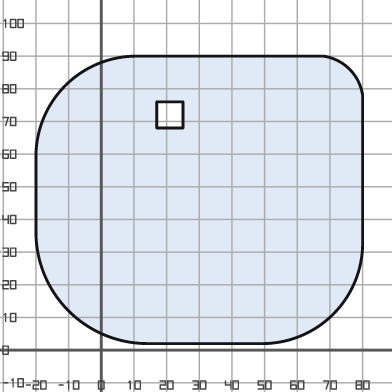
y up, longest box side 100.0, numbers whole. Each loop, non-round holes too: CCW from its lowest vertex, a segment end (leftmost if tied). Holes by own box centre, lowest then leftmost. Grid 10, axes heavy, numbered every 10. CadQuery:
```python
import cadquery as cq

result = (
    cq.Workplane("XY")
    .moveTo(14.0, 2.0)
    .lineTo(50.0, 2.0)
    .threePointArc((71.0, 11.0), (80.0, 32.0))
    .lineTo(80.0, 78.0)
    .threePointArc((76.0, 86.0), (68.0, 90.0))
    .lineTo(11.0, 90.0)
    .threePointArc((-11.0, 81.0), (-20.0, 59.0))
    .lineTo(-20.0, 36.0)
    .threePointArc((-10.0, 12.0), (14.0, 2.0))
    .close()
    .moveTo(17.0, 68.0)
    .lineTo(25.0, 68.0)
    .lineTo(25.0, 76.0)
    .lineTo(17.0, 76.0)
    .close()
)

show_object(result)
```